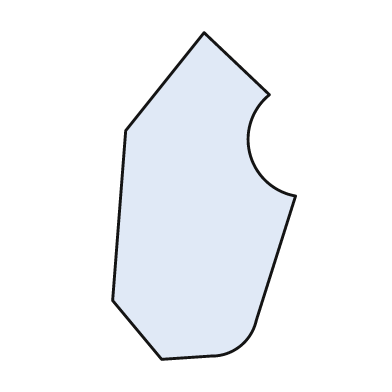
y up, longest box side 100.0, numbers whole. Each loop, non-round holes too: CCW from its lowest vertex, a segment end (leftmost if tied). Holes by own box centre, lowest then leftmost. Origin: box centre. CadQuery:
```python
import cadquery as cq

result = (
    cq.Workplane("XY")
    .moveTo(-13.0, -50.0)
    .lineTo(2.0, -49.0)
    .threePointArc((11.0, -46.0), (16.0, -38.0))
    .lineTo(28.0, 0.0)
    .threePointArc((14.0, 13.0), (20.0, 31.0))
    .lineTo(0.0, 50.0)
    .lineTo(-24.0, 20.0)
    .lineTo(-28.0, -32.0)
    .close()
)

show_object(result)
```